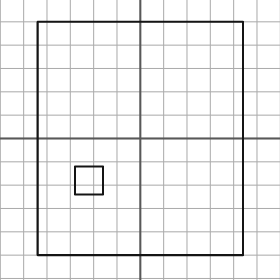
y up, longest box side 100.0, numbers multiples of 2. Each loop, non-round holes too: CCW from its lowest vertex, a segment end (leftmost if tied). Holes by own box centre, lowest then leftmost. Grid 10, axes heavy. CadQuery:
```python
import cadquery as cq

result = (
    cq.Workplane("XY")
    .moveTo(-44.0, -50.0)
    .lineTo(44.0, -50.0)
    .lineTo(44.0, 50.0)
    .lineTo(-44.0, 50.0)
    .close()
    .moveTo(-28.0, -24.0)
    .lineTo(-16.0, -24.0)
    .lineTo(-16.0, -12.0)
    .lineTo(-28.0, -12.0)
    .close()
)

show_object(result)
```